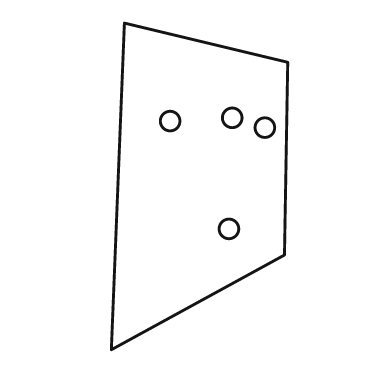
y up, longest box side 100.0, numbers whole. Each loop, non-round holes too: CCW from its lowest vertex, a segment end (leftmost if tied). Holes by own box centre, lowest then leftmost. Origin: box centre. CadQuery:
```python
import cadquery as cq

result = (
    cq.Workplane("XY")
    .moveTo(-27.0, -50.0)
    .lineTo(26.0, -21.0)
    .lineTo(27.0, 38.0)
    .lineTo(-23.0, 50.0)
    .close()
    .moveTo(9.0, -13.0)
    .circle(3.0)
    .moveTo(20.0, 18.0)
    .circle(3.0)
    .moveTo(-9.0, 20.0)
    .circle(3.0)
    .moveTo(10.0, 21.0)
    .circle(3.0)
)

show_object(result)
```